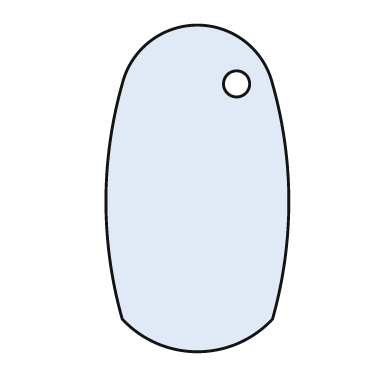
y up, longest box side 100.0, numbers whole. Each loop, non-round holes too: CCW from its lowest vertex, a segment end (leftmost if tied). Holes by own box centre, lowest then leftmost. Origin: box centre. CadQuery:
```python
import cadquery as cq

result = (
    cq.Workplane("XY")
    .moveTo(-23.0, -40.0)
    .threePointArc((0.0, -50.0), (23.0, -40.0))
    .threePointArc((28.0, -4.0), (23.0, 32.0))
    .threePointArc((0.0, 50.0), (-23.0, 32.0))
    .threePointArc((-28.0, -4.0), (-23.0, -40.0))
    .close()
    .moveTo(12.0, 32.0)
    .circle(4.0)
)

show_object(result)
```